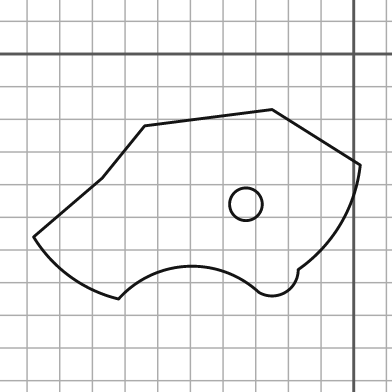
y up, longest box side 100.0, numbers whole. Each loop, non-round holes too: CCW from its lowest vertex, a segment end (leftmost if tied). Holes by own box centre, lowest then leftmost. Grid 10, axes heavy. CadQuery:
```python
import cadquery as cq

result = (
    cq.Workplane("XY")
    .moveTo(-72.0, -75.0)
    .threePointArc((-51.0, -65.0), (-29.0, -73.0))
    .threePointArc((-21.0, -73.0), (-17.0, -66.0))
    .threePointArc((-4.0, -52.0), (2.0, -34.0))
    .lineTo(-25.0, -17.0)
    .lineTo(-64.0, -22.0)
    .lineTo(-77.0, -38.0)
    .lineTo(-98.0, -56.0)
    .threePointArc((-87.0, -68.0), (-72.0, -75.0))
    .close()
    .moveTo(-33.0, -46.0)
    .circle(5.0)
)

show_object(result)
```